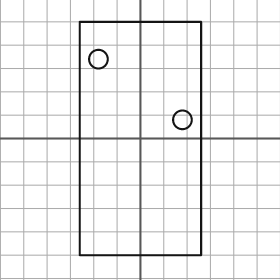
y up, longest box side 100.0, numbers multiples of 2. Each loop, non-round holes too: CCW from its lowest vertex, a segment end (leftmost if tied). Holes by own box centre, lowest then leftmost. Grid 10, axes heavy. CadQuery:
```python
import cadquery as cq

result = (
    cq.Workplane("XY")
    .moveTo(-26.0, -50.0)
    .lineTo(26.0, -50.0)
    .lineTo(26.0, 50.0)
    .lineTo(-26.0, 50.0)
    .close()
    .moveTo(18.0, 8.0)
    .circle(4.0)
    .moveTo(-18.0, 34.0)
    .circle(4.0)
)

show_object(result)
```